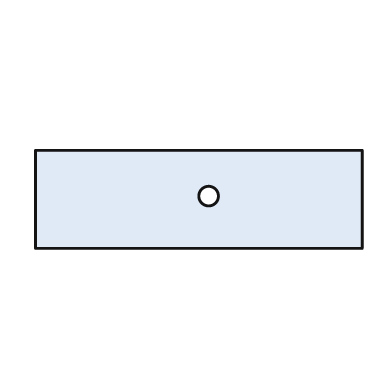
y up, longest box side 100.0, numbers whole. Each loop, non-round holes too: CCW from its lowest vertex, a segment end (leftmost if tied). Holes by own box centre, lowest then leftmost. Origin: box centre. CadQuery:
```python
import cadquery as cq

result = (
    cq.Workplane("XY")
    .moveTo(-50.0, -15.0)
    .lineTo(50.0, -15.0)
    .lineTo(50.0, 15.0)
    .lineTo(-50.0, 15.0)
    .close()
    .moveTo(3.0, 1.0)
    .circle(3.0)
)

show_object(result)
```